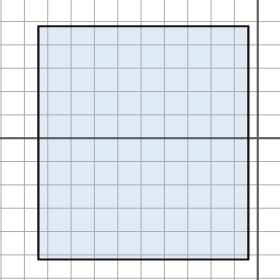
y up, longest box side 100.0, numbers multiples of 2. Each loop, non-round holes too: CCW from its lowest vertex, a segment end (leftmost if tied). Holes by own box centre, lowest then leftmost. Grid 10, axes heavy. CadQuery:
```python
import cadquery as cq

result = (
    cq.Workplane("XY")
    .moveTo(-94.0, -52.0)
    .lineTo(-4.0, -52.0)
    .lineTo(-4.0, 48.0)
    .lineTo(-94.0, 48.0)
    .close()
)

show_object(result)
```